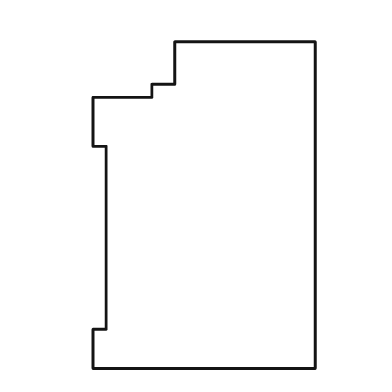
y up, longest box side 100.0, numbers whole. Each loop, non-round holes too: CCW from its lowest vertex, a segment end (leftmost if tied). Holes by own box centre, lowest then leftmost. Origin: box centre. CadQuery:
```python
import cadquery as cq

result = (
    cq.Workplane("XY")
    .moveTo(-34.0, -50.0)
    .lineTo(34.0, -50.0)
    .lineTo(34.0, 50.0)
    .lineTo(-9.0, 50.0)
    .lineTo(-9.0, 37.0)
    .lineTo(-16.0, 37.0)
    .lineTo(-16.0, 33.0)
    .lineTo(-34.0, 33.0)
    .lineTo(-34.0, 18.0)
    .lineTo(-30.0, 18.0)
    .lineTo(-30.0, -38.0)
    .lineTo(-34.0, -38.0)
    .close()
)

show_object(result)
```